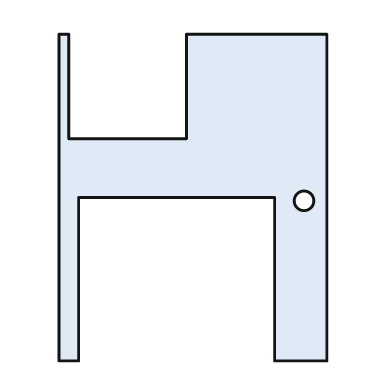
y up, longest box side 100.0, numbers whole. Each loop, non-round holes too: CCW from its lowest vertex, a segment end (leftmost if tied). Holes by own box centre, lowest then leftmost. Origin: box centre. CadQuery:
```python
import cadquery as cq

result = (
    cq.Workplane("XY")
    .moveTo(-41.0, -50.0)
    .lineTo(-35.0, -50.0)
    .lineTo(-35.0, 0.0)
    .lineTo(25.0, 0.0)
    .lineTo(25.0, -50.0)
    .lineTo(41.0, -50.0)
    .lineTo(41.0, 50.0)
    .lineTo(-2.0, 50.0)
    .lineTo(-2.0, 18.0)
    .lineTo(-38.0, 18.0)
    .lineTo(-38.0, 50.0)
    .lineTo(-41.0, 50.0)
    .close()
    .moveTo(34.0, -1.0)
    .circle(3.0)
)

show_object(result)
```